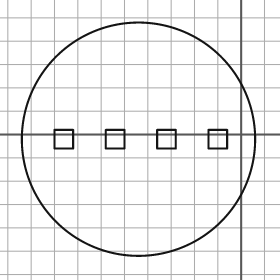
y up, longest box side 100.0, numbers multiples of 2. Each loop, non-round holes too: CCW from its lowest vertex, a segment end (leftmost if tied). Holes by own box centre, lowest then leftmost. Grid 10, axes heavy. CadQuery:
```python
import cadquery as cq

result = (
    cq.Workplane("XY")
    .moveTo(-44.0, -2.0)
    .circle(50.0)
    .moveTo(-80.0, -6.0)
    .lineTo(-72.0, -6.0)
    .lineTo(-72.0, 2.0)
    .lineTo(-80.0, 2.0)
    .close()
    .moveTo(-58.0, -6.0)
    .lineTo(-50.0, -6.0)
    .lineTo(-50.0, 2.0)
    .lineTo(-58.0, 2.0)
    .close()
    .moveTo(-36.0, -6.0)
    .lineTo(-28.0, -6.0)
    .lineTo(-28.0, 2.0)
    .lineTo(-36.0, 2.0)
    .close()
    .moveTo(-14.0, -6.0)
    .lineTo(-6.0, -6.0)
    .lineTo(-6.0, 2.0)
    .lineTo(-14.0, 2.0)
    .close()
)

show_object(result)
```